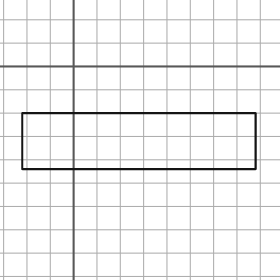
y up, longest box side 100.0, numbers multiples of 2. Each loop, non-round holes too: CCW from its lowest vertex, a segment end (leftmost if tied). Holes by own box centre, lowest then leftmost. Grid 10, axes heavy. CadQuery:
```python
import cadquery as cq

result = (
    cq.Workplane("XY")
    .moveTo(-22.0, -44.0)
    .lineTo(78.0, -44.0)
    .lineTo(78.0, -20.0)
    .lineTo(-22.0, -20.0)
    .close()
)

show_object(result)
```